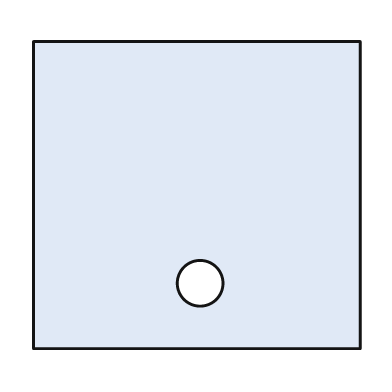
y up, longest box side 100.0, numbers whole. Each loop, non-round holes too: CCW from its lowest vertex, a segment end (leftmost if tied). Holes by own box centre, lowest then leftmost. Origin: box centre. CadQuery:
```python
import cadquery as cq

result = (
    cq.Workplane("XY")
    .moveTo(-50.0, -47.0)
    .lineTo(50.0, -47.0)
    .lineTo(50.0, 47.0)
    .lineTo(-50.0, 47.0)
    .close()
    .moveTo(1.0, -27.0)
    .circle(7.0)
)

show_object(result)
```